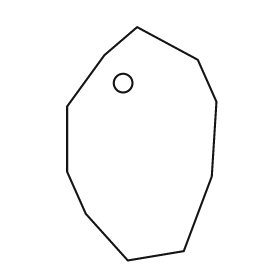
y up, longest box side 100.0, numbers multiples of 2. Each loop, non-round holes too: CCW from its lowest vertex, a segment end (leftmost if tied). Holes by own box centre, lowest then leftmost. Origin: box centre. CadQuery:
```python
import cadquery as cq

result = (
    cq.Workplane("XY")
    .moveTo(-6.0, -50.0)
    .lineTo(18.0, -46.0)
    .lineTo(30.0, -14.0)
    .lineTo(32.0, 18.0)
    .lineTo(24.0, 36.0)
    .lineTo(-2.0, 50.0)
    .lineTo(-16.0, 38.0)
    .lineTo(-32.0, 16.0)
    .lineTo(-32.0, -12.0)
    .lineTo(-24.0, -30.0)
    .close()
    .moveTo(-8.0, 26.0)
    .circle(4.0)
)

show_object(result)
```